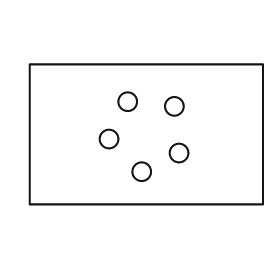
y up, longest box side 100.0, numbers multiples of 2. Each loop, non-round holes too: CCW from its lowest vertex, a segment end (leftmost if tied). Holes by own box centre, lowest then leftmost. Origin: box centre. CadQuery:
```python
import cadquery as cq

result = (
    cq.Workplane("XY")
    .moveTo(-50.0, -30.0)
    .lineTo(50.0, -30.0)
    .lineTo(50.0, 30.0)
    .lineTo(-50.0, 30.0)
    .close()
    .moveTo(-2.0, -16.0)
    .circle(4.0)
    .moveTo(14.0, -8.0)
    .circle(4.0)
    .moveTo(-16.0, -2.0)
    .circle(4.0)
    .moveTo(12.0, 12.0)
    .circle(4.0)
    .moveTo(-8.0, 14.0)
    .circle(4.0)
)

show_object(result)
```